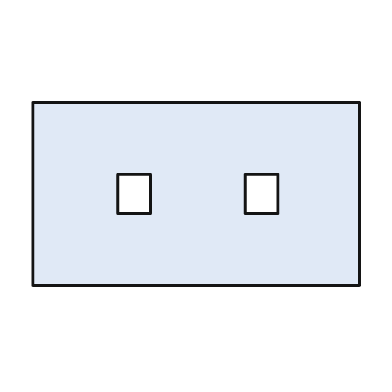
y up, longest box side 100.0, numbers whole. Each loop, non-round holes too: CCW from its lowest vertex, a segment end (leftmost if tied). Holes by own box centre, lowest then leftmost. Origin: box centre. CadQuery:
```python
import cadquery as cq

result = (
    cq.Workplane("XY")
    .moveTo(-50.0, -28.0)
    .lineTo(50.0, -28.0)
    .lineTo(50.0, 28.0)
    .lineTo(-50.0, 28.0)
    .close()
    .moveTo(-24.0, -6.0)
    .lineTo(-14.0, -6.0)
    .lineTo(-14.0, 6.0)
    .lineTo(-24.0, 6.0)
    .close()
    .moveTo(15.0, -6.0)
    .lineTo(25.0, -6.0)
    .lineTo(25.0, 6.0)
    .lineTo(15.0, 6.0)
    .close()
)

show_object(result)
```